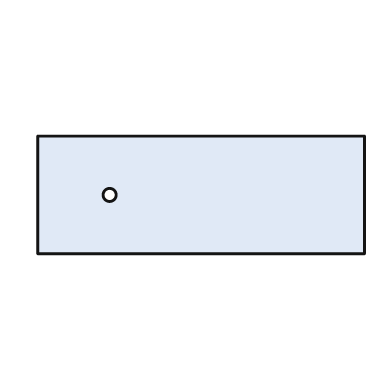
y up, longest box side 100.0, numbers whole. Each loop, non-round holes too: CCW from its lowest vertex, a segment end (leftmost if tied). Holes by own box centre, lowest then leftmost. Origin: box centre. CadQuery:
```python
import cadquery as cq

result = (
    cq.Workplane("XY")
    .moveTo(-50.0, -18.0)
    .lineTo(50.0, -18.0)
    .lineTo(50.0, 18.0)
    .lineTo(-50.0, 18.0)
    .close()
    .moveTo(-28.0, 0.0)
    .circle(2.0)
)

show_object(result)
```